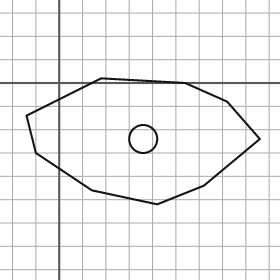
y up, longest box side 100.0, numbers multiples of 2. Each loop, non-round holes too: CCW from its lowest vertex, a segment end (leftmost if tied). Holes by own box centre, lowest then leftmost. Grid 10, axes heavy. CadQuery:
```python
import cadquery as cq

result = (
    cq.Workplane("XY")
    .moveTo(42.0, -52.0)
    .lineTo(62.0, -44.0)
    .lineTo(86.0, -24.0)
    .lineTo(72.0, -8.0)
    .lineTo(54.0, 0.0)
    .lineTo(18.0, 2.0)
    .lineTo(-14.0, -14.0)
    .lineTo(-10.0, -30.0)
    .lineTo(14.0, -46.0)
    .close()
    .moveTo(36.0, -24.0)
    .circle(6.0)
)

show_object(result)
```